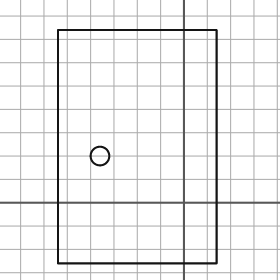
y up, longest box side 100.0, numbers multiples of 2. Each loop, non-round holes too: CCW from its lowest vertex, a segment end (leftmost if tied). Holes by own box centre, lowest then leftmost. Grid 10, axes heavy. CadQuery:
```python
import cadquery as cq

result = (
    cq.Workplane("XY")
    .moveTo(-54.0, -26.0)
    .lineTo(14.0, -26.0)
    .lineTo(14.0, 74.0)
    .lineTo(-54.0, 74.0)
    .close()
    .moveTo(-36.0, 20.0)
    .circle(4.0)
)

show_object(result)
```